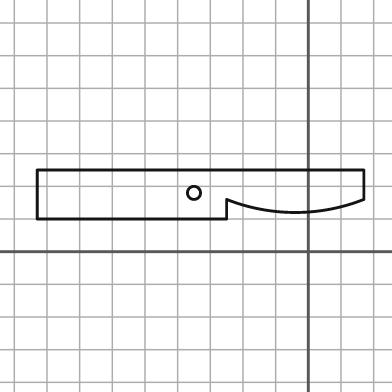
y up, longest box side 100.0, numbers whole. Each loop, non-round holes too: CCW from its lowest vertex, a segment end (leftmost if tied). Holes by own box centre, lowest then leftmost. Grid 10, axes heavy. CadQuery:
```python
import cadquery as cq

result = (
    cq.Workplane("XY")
    .moveTo(-83.0, 10.0)
    .lineTo(-25.0, 10.0)
    .lineTo(-25.0, 16.0)
    .threePointArc((-4.0, 12.0), (17.0, 16.0))
    .lineTo(17.0, 25.0)
    .lineTo(-83.0, 25.0)
    .close()
    .moveTo(-35.0, 18.0)
    .circle(2.0)
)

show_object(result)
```